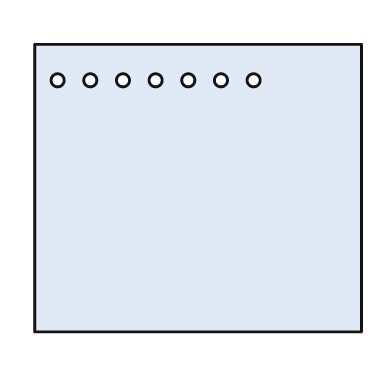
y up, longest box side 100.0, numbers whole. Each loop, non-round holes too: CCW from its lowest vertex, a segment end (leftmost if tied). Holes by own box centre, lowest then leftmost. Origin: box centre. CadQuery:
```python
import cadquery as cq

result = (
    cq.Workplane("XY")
    .moveTo(-50.0, -44.0)
    .lineTo(50.0, -44.0)
    .lineTo(50.0, 44.0)
    .lineTo(-50.0, 44.0)
    .close()
    .moveTo(-43.0, 33.0)
    .circle(2.0)
    .moveTo(-33.0, 33.0)
    .circle(2.0)
    .moveTo(-23.0, 33.0)
    .circle(2.0)
    .moveTo(-13.0, 33.0)
    .circle(2.0)
    .moveTo(-3.0, 33.0)
    .circle(2.0)
    .moveTo(7.0, 33.0)
    .circle(2.0)
    .moveTo(17.0, 33.0)
    .circle(2.0)
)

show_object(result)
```